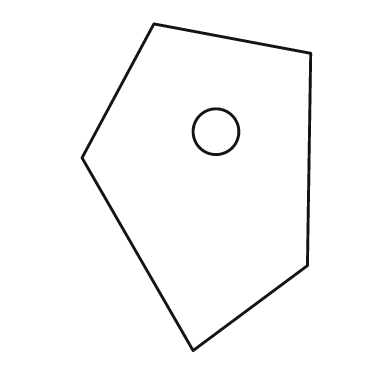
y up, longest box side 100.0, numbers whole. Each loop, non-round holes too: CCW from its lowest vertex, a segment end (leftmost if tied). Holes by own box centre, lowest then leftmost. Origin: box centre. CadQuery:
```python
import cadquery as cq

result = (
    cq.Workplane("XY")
    .moveTo(-1.0, -50.0)
    .lineTo(34.0, -24.0)
    .lineTo(35.0, 41.0)
    .lineTo(-13.0, 50.0)
    .lineTo(-35.0, 9.0)
    .close()
    .moveTo(6.0, 17.0)
    .circle(7.0)
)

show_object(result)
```